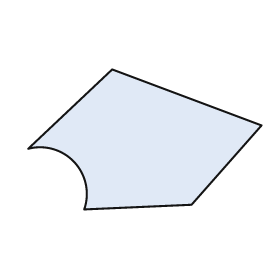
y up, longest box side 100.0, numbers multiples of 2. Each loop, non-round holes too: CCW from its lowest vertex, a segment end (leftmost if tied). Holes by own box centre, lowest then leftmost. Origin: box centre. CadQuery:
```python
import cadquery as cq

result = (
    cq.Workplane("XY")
    .moveTo(-26.0, -30.0)
    .lineTo(20.0, -28.0)
    .lineTo(50.0, 6.0)
    .lineTo(-14.0, 30.0)
    .lineTo(-50.0, -4.0)
    .threePointArc((-30.0, -10.0), (-26.0, -30.0))
    .close()
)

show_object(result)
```